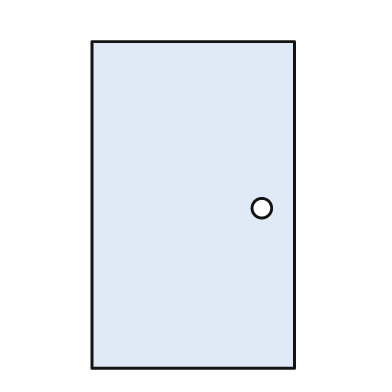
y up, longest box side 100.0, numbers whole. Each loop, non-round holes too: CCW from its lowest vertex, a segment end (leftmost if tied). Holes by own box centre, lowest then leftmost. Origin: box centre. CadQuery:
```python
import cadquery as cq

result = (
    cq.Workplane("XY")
    .moveTo(-31.0, -50.0)
    .lineTo(31.0, -50.0)
    .lineTo(31.0, 50.0)
    .lineTo(-31.0, 50.0)
    .close()
    .moveTo(21.0, -1.0)
    .circle(3.0)
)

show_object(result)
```